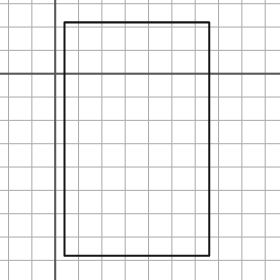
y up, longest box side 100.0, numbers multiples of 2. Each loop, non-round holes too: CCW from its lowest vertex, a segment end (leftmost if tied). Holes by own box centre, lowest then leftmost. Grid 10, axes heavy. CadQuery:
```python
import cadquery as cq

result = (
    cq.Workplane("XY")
    .moveTo(4.0, -78.0)
    .lineTo(66.0, -78.0)
    .lineTo(66.0, 22.0)
    .lineTo(4.0, 22.0)
    .close()
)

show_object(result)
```